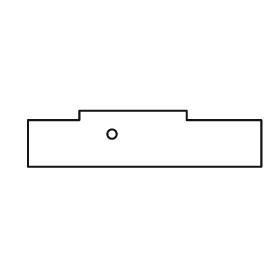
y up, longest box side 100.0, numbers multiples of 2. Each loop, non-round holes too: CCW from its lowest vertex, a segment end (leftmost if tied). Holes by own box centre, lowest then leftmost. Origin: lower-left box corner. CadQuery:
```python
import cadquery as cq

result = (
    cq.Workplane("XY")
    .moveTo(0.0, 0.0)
    .lineTo(100.0, 0.0)
    .lineTo(100.0, 20.0)
    .lineTo(68.0, 20.0)
    .lineTo(68.0, 24.0)
    .lineTo(22.0, 24.0)
    .lineTo(22.0, 20.0)
    .lineTo(0.0, 20.0)
    .close()
    .moveTo(36.0, 14.0)
    .circle(2.0)
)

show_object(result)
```